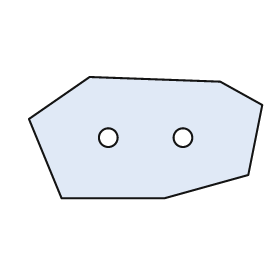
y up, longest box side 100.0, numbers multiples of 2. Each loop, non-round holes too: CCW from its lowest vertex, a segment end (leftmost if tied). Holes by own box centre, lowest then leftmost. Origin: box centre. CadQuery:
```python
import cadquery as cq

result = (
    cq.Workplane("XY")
    .moveTo(-36.0, -26.0)
    .lineTo(8.0, -26.0)
    .lineTo(44.0, -16.0)
    .lineTo(50.0, 14.0)
    .lineTo(32.0, 24.0)
    .lineTo(-24.0, 26.0)
    .lineTo(-50.0, 8.0)
    .close()
    .moveTo(-16.0, 0.0)
    .circle(4.0)
    .moveTo(16.0, 0.0)
    .circle(4.0)
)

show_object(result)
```